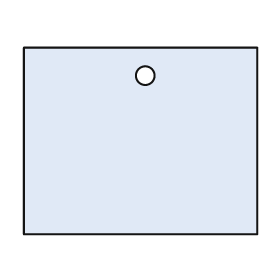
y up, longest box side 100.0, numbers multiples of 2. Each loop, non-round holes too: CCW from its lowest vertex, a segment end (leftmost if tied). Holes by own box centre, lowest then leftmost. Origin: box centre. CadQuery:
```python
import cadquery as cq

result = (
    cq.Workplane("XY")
    .moveTo(-50.0, -40.0)
    .lineTo(50.0, -40.0)
    .lineTo(50.0, 40.0)
    .lineTo(-50.0, 40.0)
    .close()
    .moveTo(2.0, 28.0)
    .circle(4.0)
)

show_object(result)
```